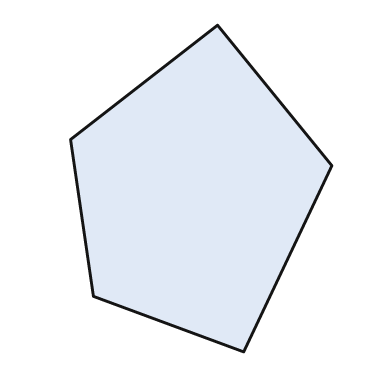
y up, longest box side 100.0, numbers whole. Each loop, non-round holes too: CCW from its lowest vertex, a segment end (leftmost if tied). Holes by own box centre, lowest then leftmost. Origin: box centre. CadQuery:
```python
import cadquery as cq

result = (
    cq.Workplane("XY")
    .moveTo(13.0, -50.0)
    .lineTo(40.0, 7.0)
    .lineTo(5.0, 50.0)
    .lineTo(-40.0, 15.0)
    .lineTo(-33.0, -33.0)
    .close()
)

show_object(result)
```